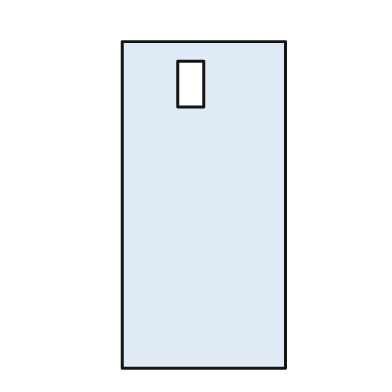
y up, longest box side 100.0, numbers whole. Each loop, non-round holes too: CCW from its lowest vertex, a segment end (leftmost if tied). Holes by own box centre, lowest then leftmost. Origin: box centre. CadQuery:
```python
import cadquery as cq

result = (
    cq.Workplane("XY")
    .moveTo(-25.0, -50.0)
    .lineTo(25.0, -50.0)
    .lineTo(25.0, 50.0)
    .lineTo(-25.0, 50.0)
    .close()
    .moveTo(-8.0, 30.0)
    .lineTo(0.0, 30.0)
    .lineTo(0.0, 44.0)
    .lineTo(-8.0, 44.0)
    .close()
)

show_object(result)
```